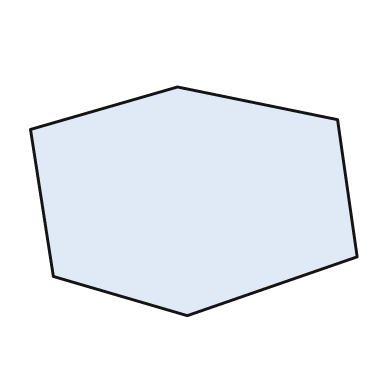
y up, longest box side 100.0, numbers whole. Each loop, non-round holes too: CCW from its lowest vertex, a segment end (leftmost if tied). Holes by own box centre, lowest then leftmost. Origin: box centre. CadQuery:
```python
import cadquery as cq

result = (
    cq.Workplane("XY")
    .moveTo(-2.0, -35.0)
    .lineTo(50.0, -17.0)
    .lineTo(44.0, 25.0)
    .lineTo(-5.0, 35.0)
    .lineTo(-50.0, 22.0)
    .lineTo(-43.0, -23.0)
    .close()
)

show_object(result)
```